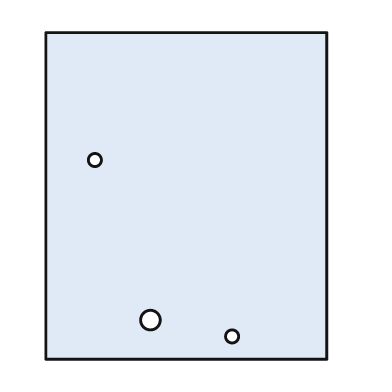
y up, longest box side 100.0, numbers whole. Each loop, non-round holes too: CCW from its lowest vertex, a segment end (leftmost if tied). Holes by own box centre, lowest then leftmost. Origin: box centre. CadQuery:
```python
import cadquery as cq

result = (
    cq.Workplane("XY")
    .moveTo(-43.0, -50.0)
    .lineTo(43.0, -50.0)
    .lineTo(43.0, 50.0)
    .lineTo(-43.0, 50.0)
    .close()
    .moveTo(14.0, -43.0)
    .circle(2.0)
    .moveTo(-11.0, -38.0)
    .circle(3.0)
    .moveTo(-28.0, 11.0)
    .circle(2.0)
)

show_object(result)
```